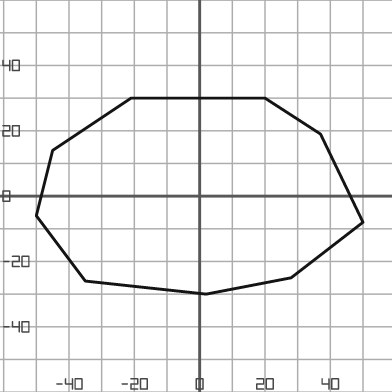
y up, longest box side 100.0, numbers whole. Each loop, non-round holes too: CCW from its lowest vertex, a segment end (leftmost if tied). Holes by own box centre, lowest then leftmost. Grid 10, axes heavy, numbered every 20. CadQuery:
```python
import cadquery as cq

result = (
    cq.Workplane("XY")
    .moveTo(2.0, -30.0)
    .lineTo(28.0, -25.0)
    .lineTo(50.0, -8.0)
    .lineTo(37.0, 19.0)
    .lineTo(20.0, 30.0)
    .lineTo(-21.0, 30.0)
    .lineTo(-45.0, 14.0)
    .lineTo(-50.0, -6.0)
    .lineTo(-35.0, -26.0)
    .close()
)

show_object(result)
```